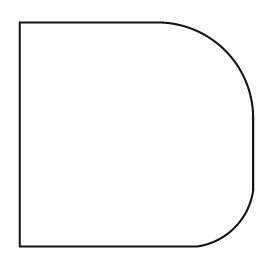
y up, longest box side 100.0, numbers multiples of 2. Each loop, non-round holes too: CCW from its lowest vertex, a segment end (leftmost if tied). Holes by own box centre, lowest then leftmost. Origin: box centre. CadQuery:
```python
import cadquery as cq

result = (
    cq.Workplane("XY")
    .moveTo(-50.0, -48.0)
    .lineTo(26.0, -48.0)
    .threePointArc((42.0, -40.0), (50.0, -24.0))
    .lineTo(50.0, 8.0)
    .threePointArc((38.0, 36.0), (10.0, 48.0))
    .lineTo(-50.0, 48.0)
    .close()
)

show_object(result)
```